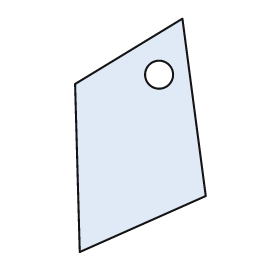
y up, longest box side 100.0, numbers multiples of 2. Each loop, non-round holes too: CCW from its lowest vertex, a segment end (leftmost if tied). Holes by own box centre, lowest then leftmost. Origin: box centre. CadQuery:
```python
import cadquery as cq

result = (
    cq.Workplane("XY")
    .moveTo(-26.0, -50.0)
    .lineTo(28.0, -26.0)
    .lineTo(18.0, 50.0)
    .lineTo(-28.0, 22.0)
    .close()
    .moveTo(8.0, 26.0)
    .circle(6.0)
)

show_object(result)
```